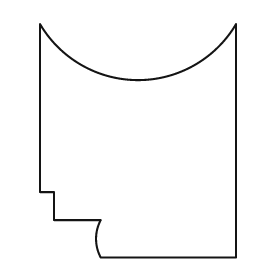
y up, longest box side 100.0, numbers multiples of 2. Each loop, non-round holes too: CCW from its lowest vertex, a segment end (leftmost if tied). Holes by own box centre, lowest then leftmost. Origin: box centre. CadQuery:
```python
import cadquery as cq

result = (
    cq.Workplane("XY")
    .moveTo(-16.0, -50.0)
    .lineTo(42.0, -50.0)
    .lineTo(42.0, 50.0)
    .threePointArc((0.0, 26.0), (-42.0, 50.0))
    .lineTo(-42.0, -22.0)
    .lineTo(-36.0, -22.0)
    .lineTo(-36.0, -34.0)
    .lineTo(-16.0, -34.0)
    .threePointArc((-18.0, -42.0), (-16.0, -50.0))
    .close()
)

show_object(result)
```